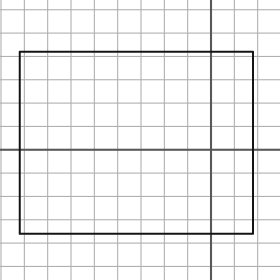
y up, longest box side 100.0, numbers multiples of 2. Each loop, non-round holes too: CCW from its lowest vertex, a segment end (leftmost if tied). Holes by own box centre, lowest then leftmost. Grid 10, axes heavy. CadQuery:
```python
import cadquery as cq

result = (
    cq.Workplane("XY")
    .moveTo(-82.0, -36.0)
    .lineTo(18.0, -36.0)
    .lineTo(18.0, 42.0)
    .lineTo(-82.0, 42.0)
    .close()
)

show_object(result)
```